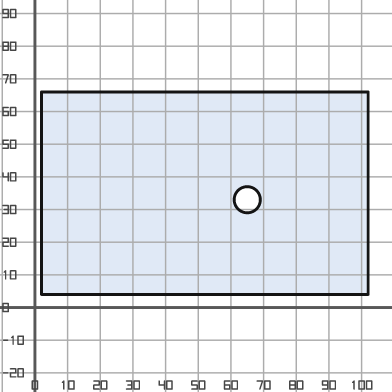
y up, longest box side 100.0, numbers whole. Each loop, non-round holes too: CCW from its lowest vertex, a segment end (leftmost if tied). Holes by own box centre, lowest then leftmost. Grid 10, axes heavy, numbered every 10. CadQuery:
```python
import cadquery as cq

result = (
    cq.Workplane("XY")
    .moveTo(2.0, 4.0)
    .lineTo(102.0, 4.0)
    .lineTo(102.0, 66.0)
    .lineTo(2.0, 66.0)
    .close()
    .moveTo(65.0, 33.0)
    .circle(4.0)
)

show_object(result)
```